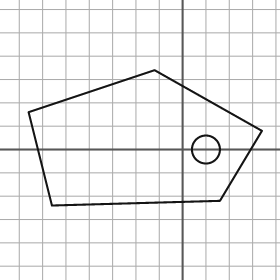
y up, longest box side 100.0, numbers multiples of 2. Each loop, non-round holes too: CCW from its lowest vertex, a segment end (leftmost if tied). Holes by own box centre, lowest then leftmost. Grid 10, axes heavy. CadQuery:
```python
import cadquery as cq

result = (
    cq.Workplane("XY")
    .moveTo(-56.0, -24.0)
    .lineTo(16.0, -22.0)
    .lineTo(34.0, 8.0)
    .lineTo(-12.0, 34.0)
    .lineTo(-66.0, 16.0)
    .close()
    .moveTo(10.0, 0.0)
    .circle(6.0)
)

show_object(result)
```